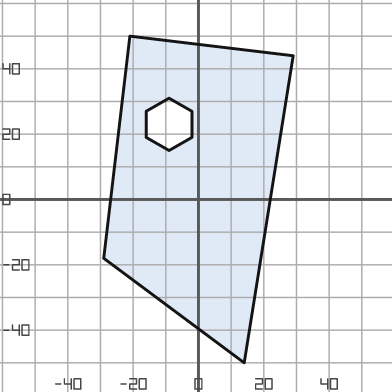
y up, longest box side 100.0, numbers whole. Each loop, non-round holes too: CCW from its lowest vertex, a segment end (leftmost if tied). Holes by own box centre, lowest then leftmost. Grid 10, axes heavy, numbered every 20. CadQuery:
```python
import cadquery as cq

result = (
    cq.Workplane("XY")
    .moveTo(14.0, -50.0)
    .lineTo(29.0, 44.0)
    .lineTo(-21.0, 50.0)
    .lineTo(-29.0, -18.0)
    .close()
    .moveTo(-9.0, 15.0)
    .lineTo(-2.0, 19.0)
    .lineTo(-2.0, 27.0)
    .lineTo(-9.0, 31.0)
    .lineTo(-16.0, 27.0)
    .lineTo(-16.0, 19.0)
    .close()
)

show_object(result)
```